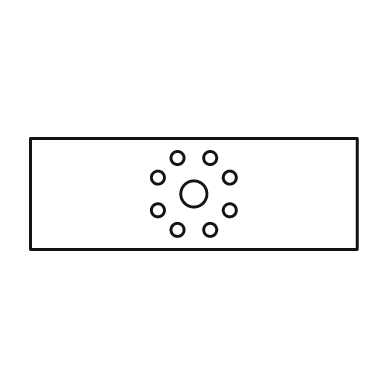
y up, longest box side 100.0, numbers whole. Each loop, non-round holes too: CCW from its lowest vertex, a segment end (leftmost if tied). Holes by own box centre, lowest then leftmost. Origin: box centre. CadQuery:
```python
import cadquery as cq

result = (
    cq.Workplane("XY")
    .moveTo(-50.0, -17.0)
    .lineTo(50.0, -17.0)
    .lineTo(50.0, 17.0)
    .lineTo(-50.0, 17.0)
    .close()
    .moveTo(-5.0, -11.0)
    .circle(2.0)
    .moveTo(5.0, -11.0)
    .circle(2.0)
    .moveTo(-11.0, -5.0)
    .circle(2.0)
    .moveTo(11.0, -5.0)
    .circle(2.0)
    .moveTo(0.0, 0.0)
    .circle(4.0)
    .moveTo(-11.0, 5.0)
    .circle(2.0)
    .moveTo(11.0, 5.0)
    .circle(2.0)
    .moveTo(-5.0, 11.0)
    .circle(2.0)
    .moveTo(5.0, 11.0)
    .circle(2.0)
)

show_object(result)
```